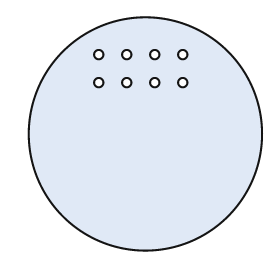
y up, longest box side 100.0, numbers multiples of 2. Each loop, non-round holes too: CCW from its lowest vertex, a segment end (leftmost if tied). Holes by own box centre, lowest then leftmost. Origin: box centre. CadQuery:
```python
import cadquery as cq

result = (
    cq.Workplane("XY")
    .moveTo(0.0, 0.0)
    .circle(50.0)
    .moveTo(-20.0, 22.0)
    .circle(2.0)
    .moveTo(-8.0, 22.0)
    .circle(2.0)
    .moveTo(4.0, 22.0)
    .circle(2.0)
    .moveTo(16.0, 22.0)
    .circle(2.0)
    .moveTo(-20.0, 34.0)
    .circle(2.0)
    .moveTo(-8.0, 34.0)
    .circle(2.0)
    .moveTo(4.0, 34.0)
    .circle(2.0)
    .moveTo(16.0, 34.0)
    .circle(2.0)
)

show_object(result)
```